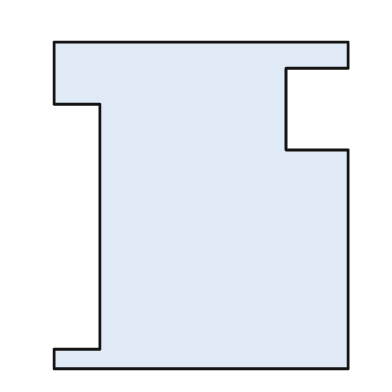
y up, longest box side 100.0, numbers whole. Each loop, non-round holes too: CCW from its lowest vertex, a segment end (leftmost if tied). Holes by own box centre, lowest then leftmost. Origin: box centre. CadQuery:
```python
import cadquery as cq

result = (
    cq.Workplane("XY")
    .moveTo(-45.0, -50.0)
    .lineTo(45.0, -50.0)
    .lineTo(45.0, 17.0)
    .lineTo(26.0, 17.0)
    .lineTo(26.0, 42.0)
    .lineTo(45.0, 42.0)
    .lineTo(45.0, 50.0)
    .lineTo(-45.0, 50.0)
    .lineTo(-45.0, 31.0)
    .lineTo(-31.0, 31.0)
    .lineTo(-31.0, -44.0)
    .lineTo(-45.0, -44.0)
    .close()
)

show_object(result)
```